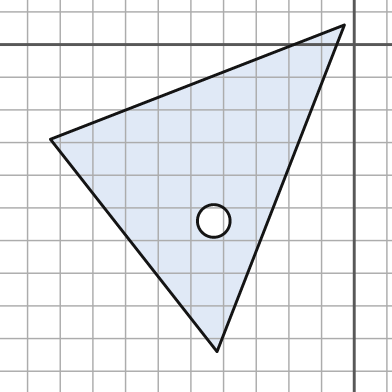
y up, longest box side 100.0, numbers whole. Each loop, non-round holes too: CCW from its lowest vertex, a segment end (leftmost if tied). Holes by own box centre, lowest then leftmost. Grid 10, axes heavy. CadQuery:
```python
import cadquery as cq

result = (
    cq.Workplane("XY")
    .moveTo(-42.0, -94.0)
    .lineTo(-3.0, 6.0)
    .lineTo(-93.0, -29.0)
    .close()
    .moveTo(-43.0, -54.0)
    .circle(5.0)
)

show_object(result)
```